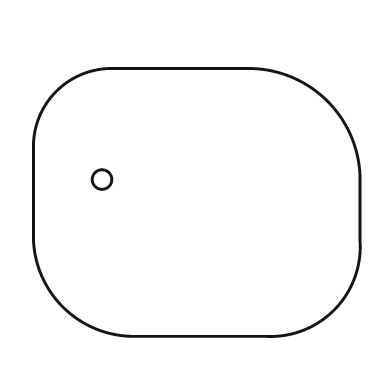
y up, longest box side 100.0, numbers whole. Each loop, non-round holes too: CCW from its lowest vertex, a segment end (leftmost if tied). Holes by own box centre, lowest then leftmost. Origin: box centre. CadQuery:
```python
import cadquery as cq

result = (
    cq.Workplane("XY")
    .moveTo(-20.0, -41.0)
    .lineTo(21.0, -41.0)
    .threePointArc((42.0, -33.0), (50.0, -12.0))
    .lineTo(50.0, 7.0)
    .threePointArc((40.0, 31.0), (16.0, 41.0))
    .lineTo(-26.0, 41.0)
    .threePointArc((-43.0, 34.0), (-50.0, 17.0))
    .lineTo(-50.0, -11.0)
    .threePointArc((-41.0, -32.0), (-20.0, -41.0))
    .close()
    .moveTo(-29.0, 7.0)
    .circle(3.0)
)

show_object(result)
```